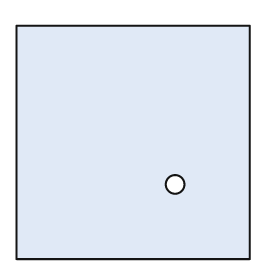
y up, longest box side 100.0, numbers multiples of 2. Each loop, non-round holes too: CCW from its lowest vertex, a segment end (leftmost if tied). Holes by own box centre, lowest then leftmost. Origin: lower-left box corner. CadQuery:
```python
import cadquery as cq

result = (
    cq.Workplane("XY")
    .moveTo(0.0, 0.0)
    .lineTo(100.0, 0.0)
    .lineTo(100.0, 100.0)
    .lineTo(0.0, 100.0)
    .close()
    .moveTo(68.0, 32.0)
    .circle(4.0)
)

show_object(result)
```